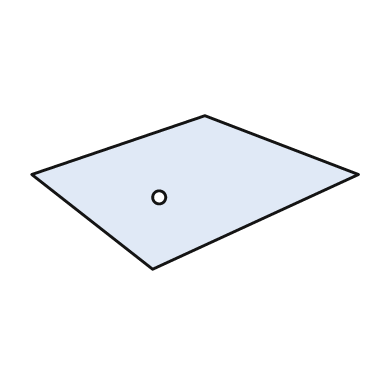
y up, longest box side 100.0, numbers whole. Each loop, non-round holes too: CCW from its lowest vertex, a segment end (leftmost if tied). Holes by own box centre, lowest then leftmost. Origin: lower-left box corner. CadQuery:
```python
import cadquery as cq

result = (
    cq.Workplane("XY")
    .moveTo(37.0, 0.0)
    .lineTo(100.0, 29.0)
    .lineTo(53.0, 47.0)
    .lineTo(0.0, 29.0)
    .close()
    .moveTo(39.0, 22.0)
    .circle(2.0)
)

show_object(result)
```